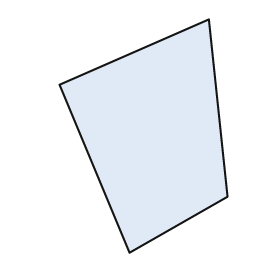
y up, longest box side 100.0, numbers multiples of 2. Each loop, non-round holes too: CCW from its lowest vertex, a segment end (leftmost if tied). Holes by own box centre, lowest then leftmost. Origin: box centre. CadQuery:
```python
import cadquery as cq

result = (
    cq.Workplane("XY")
    .moveTo(-6.0, -50.0)
    .lineTo(36.0, -26.0)
    .lineTo(28.0, 50.0)
    .lineTo(-36.0, 22.0)
    .close()
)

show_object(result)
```